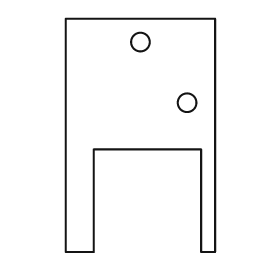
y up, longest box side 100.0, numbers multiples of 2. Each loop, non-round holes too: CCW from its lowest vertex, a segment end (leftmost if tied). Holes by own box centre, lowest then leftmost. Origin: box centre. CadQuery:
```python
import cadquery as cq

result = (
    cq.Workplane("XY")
    .moveTo(-32.0, -50.0)
    .lineTo(-20.0, -50.0)
    .lineTo(-20.0, -6.0)
    .lineTo(26.0, -6.0)
    .lineTo(26.0, -50.0)
    .lineTo(32.0, -50.0)
    .lineTo(32.0, 50.0)
    .lineTo(-32.0, 50.0)
    .close()
    .moveTo(20.0, 14.0)
    .circle(4.0)
    .moveTo(0.0, 40.0)
    .circle(4.0)
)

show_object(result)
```